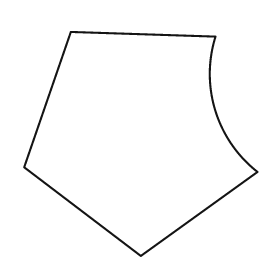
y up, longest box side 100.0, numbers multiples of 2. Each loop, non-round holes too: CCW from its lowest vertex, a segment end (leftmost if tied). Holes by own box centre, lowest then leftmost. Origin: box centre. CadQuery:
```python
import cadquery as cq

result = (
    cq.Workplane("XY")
    .moveTo(0.0, -48.0)
    .lineTo(50.0, -12.0)
    .threePointArc((32.0, 14.0), (32.0, 46.0))
    .lineTo(-30.0, 48.0)
    .lineTo(-50.0, -10.0)
    .close()
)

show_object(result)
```